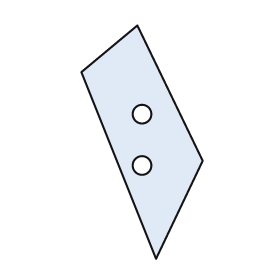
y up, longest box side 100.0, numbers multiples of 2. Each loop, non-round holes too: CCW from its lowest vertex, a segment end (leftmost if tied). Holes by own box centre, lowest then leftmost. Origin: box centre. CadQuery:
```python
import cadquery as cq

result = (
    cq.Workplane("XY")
    .moveTo(6.0, -50.0)
    .lineTo(26.0, -8.0)
    .lineTo(-2.0, 50.0)
    .lineTo(-26.0, 30.0)
    .close()
    .moveTo(0.0, -10.0)
    .circle(4.0)
    .moveTo(0.0, 12.0)
    .circle(4.0)
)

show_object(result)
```